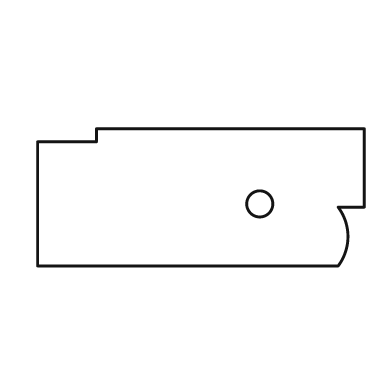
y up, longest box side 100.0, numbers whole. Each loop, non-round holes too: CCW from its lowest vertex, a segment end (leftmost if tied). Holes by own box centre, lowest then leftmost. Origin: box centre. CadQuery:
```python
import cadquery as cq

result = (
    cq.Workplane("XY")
    .moveTo(-50.0, -21.0)
    .lineTo(42.0, -21.0)
    .threePointArc((45.0, -12.0), (42.0, -3.0))
    .lineTo(50.0, -3.0)
    .lineTo(50.0, 21.0)
    .lineTo(-32.0, 21.0)
    .lineTo(-32.0, 17.0)
    .lineTo(-50.0, 17.0)
    .close()
    .moveTo(18.0, -2.0)
    .circle(4.0)
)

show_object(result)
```